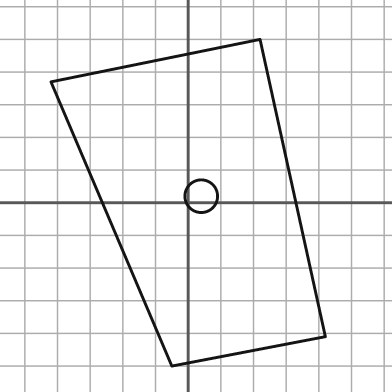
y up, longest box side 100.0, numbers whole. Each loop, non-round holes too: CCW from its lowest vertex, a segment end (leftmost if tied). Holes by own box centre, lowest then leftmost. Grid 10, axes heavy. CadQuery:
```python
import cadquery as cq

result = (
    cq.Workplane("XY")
    .moveTo(-5.0, -50.0)
    .lineTo(42.0, -41.0)
    .lineTo(22.0, 50.0)
    .lineTo(-42.0, 37.0)
    .close()
    .moveTo(4.0, 2.0)
    .circle(5.0)
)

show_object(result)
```